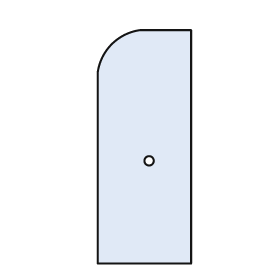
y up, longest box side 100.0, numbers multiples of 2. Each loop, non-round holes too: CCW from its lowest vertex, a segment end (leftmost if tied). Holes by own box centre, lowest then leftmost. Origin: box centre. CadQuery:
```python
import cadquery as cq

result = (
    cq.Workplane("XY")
    .moveTo(-20.0, -50.0)
    .lineTo(20.0, -50.0)
    .lineTo(20.0, 50.0)
    .lineTo(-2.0, 50.0)
    .threePointArc((-14.0, 44.0), (-20.0, 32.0))
    .close()
    .moveTo(2.0, -6.0)
    .circle(2.0)
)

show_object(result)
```